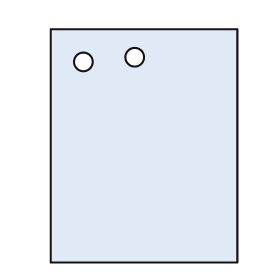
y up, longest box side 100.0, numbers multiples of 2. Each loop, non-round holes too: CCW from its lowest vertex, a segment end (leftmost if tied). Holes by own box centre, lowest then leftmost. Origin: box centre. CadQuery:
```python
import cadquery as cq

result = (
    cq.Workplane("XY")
    .moveTo(-40.0, -50.0)
    .lineTo(40.0, -50.0)
    .lineTo(40.0, 50.0)
    .lineTo(-40.0, 50.0)
    .close()
    .moveTo(-26.0, 36.0)
    .circle(4.0)
    .moveTo(-4.0, 38.0)
    .circle(4.0)
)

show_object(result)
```